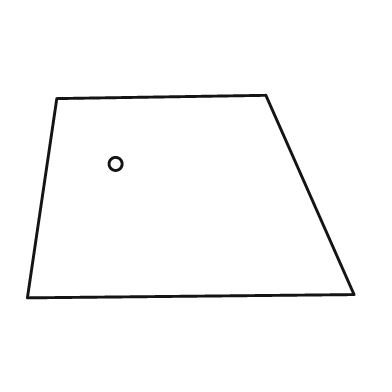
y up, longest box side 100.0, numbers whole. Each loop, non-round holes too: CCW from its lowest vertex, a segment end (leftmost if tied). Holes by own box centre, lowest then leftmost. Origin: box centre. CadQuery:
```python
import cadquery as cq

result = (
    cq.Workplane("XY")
    .moveTo(-50.0, -31.0)
    .lineTo(50.0, -30.0)
    .lineTo(23.0, 31.0)
    .lineTo(-41.0, 30.0)
    .close()
    .moveTo(-23.0, 10.0)
    .circle(2.0)
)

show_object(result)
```